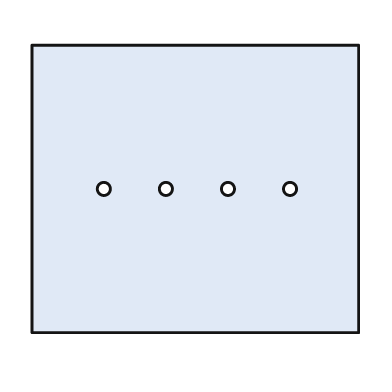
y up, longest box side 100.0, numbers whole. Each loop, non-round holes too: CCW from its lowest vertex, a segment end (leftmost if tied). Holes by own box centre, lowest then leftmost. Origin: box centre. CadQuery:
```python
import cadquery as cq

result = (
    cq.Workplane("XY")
    .moveTo(-50.0, -44.0)
    .lineTo(50.0, -44.0)
    .lineTo(50.0, 44.0)
    .lineTo(-50.0, 44.0)
    .close()
    .moveTo(-28.0, 0.0)
    .circle(2.0)
    .moveTo(-9.0, 0.0)
    .circle(2.0)
    .moveTo(10.0, 0.0)
    .circle(2.0)
    .moveTo(29.0, 0.0)
    .circle(2.0)
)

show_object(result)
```